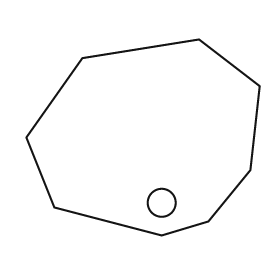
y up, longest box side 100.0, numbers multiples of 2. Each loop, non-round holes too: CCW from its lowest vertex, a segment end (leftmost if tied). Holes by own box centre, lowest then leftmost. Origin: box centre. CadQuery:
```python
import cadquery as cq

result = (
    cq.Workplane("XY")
    .moveTo(8.0, -42.0)
    .lineTo(28.0, -36.0)
    .lineTo(46.0, -14.0)
    .lineTo(50.0, 22.0)
    .lineTo(24.0, 42.0)
    .lineTo(-26.0, 34.0)
    .lineTo(-50.0, 0.0)
    .lineTo(-38.0, -30.0)
    .close()
    .moveTo(8.0, -28.0)
    .circle(6.0)
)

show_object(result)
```